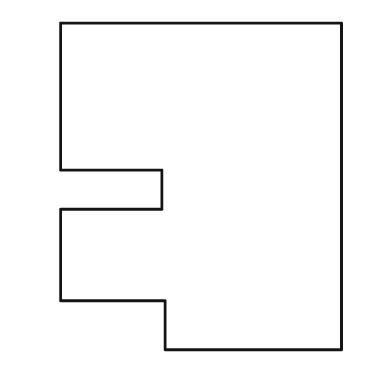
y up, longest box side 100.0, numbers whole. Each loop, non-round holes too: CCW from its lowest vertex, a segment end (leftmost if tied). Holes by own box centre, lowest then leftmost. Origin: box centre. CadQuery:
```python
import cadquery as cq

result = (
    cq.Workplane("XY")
    .moveTo(-11.0, -50.0)
    .lineTo(43.0, -50.0)
    .lineTo(43.0, 50.0)
    .lineTo(-43.0, 50.0)
    .lineTo(-43.0, 5.0)
    .lineTo(-12.0, 5.0)
    .lineTo(-12.0, -7.0)
    .lineTo(-43.0, -7.0)
    .lineTo(-43.0, -35.0)
    .lineTo(-11.0, -35.0)
    .close()
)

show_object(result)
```